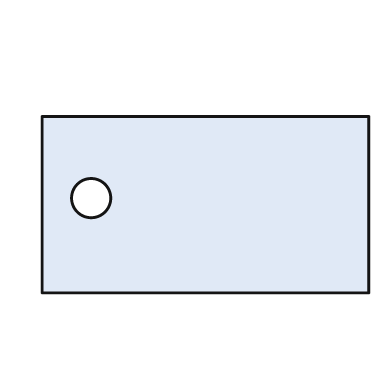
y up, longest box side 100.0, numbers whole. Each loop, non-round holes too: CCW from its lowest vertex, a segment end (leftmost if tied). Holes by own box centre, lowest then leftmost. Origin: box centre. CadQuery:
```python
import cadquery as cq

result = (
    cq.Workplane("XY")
    .moveTo(-50.0, -27.0)
    .lineTo(50.0, -27.0)
    .lineTo(50.0, 27.0)
    .lineTo(-50.0, 27.0)
    .close()
    .moveTo(-35.0, 2.0)
    .circle(6.0)
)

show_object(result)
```